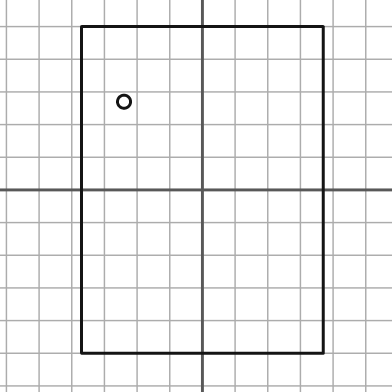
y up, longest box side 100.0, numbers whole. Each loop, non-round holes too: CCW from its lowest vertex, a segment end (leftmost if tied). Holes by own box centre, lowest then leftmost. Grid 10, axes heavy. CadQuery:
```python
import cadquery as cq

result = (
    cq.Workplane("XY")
    .moveTo(-37.0, -50.0)
    .lineTo(37.0, -50.0)
    .lineTo(37.0, 50.0)
    .lineTo(-37.0, 50.0)
    .close()
    .moveTo(-24.0, 27.0)
    .circle(2.0)
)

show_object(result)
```